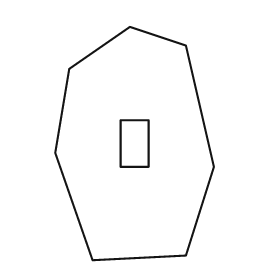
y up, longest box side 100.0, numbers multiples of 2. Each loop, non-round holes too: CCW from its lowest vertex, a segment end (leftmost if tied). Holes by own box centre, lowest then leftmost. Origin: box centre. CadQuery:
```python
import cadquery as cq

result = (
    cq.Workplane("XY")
    .moveTo(-18.0, -50.0)
    .lineTo(22.0, -48.0)
    .lineTo(34.0, -10.0)
    .lineTo(22.0, 42.0)
    .lineTo(-2.0, 50.0)
    .lineTo(-28.0, 32.0)
    .lineTo(-34.0, -4.0)
    .close()
    .moveTo(-6.0, -10.0)
    .lineTo(6.0, -10.0)
    .lineTo(6.0, 10.0)
    .lineTo(-6.0, 10.0)
    .close()
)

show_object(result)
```